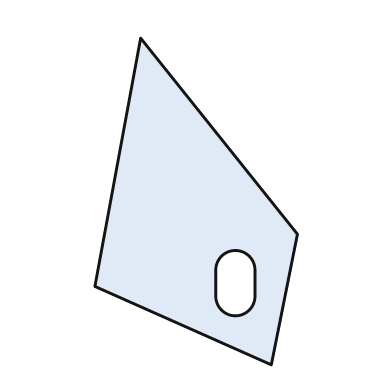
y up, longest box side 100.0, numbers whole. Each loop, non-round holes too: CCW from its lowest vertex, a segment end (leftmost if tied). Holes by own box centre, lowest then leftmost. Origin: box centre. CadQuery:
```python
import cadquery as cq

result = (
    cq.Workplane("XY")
    .moveTo(23.0, -50.0)
    .lineTo(31.0, -10.0)
    .lineTo(-17.0, 50.0)
    .lineTo(-31.0, -26.0)
    .close()
    .moveTo(6.0, -29.0)
    .threePointArc((12.0, -35.0), (18.0, -29.0))
    .lineTo(18.0, -21.0)
    .threePointArc((12.0, -15.0), (6.0, -21.0))
    .close()
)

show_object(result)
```